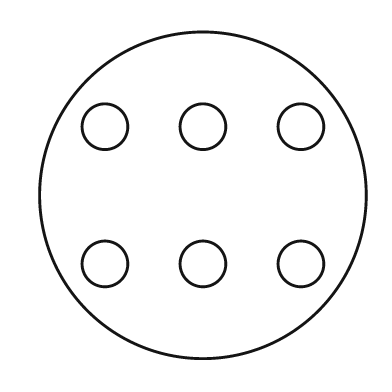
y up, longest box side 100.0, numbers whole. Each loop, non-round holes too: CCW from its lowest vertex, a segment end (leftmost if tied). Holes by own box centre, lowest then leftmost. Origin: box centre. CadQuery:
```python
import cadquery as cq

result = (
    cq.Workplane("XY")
    .moveTo(0.0, 0.0)
    .circle(50.0)
    .moveTo(-30.0, -21.0)
    .circle(7.0)
    .moveTo(0.0, -21.0)
    .circle(7.0)
    .moveTo(30.0, -21.0)
    .circle(7.0)
    .moveTo(-30.0, 21.0)
    .circle(7.0)
    .moveTo(0.0, 21.0)
    .circle(7.0)
    .moveTo(30.0, 21.0)
    .circle(7.0)
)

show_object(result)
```